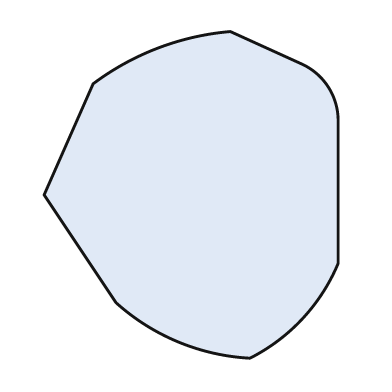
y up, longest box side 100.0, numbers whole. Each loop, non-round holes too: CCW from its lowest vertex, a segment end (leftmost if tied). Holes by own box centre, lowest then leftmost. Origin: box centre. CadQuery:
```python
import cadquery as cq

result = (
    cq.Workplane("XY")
    .moveTo(18.0, -50.0)
    .threePointArc((34.0, -38.0), (45.0, -21.0))
    .lineTo(45.0, 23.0)
    .threePointArc((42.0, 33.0), (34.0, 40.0))
    .lineTo(12.0, 50.0)
    .threePointArc((-10.0, 45.0), (-30.0, 34.0))
    .lineTo(-45.0, 0.0)
    .lineTo(-23.0, -33.0)
    .threePointArc((-4.0, -45.0), (18.0, -50.0))
    .close()
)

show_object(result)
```